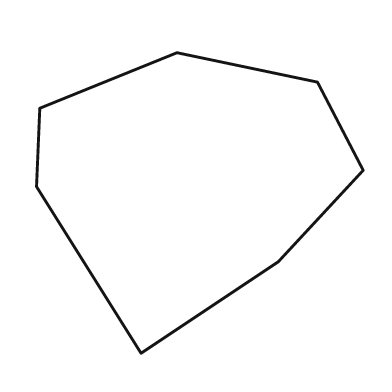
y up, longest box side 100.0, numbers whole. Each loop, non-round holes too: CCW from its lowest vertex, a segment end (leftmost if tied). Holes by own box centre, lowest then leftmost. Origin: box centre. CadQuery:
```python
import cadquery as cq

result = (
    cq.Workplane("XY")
    .moveTo(-18.0, -46.0)
    .lineTo(24.0, -18.0)
    .lineTo(50.0, 10.0)
    .lineTo(36.0, 37.0)
    .lineTo(-7.0, 46.0)
    .lineTo(-49.0, 29.0)
    .lineTo(-50.0, 5.0)
    .close()
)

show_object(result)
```